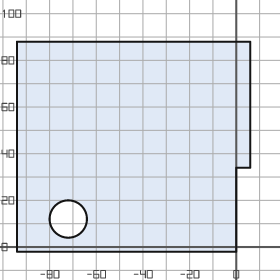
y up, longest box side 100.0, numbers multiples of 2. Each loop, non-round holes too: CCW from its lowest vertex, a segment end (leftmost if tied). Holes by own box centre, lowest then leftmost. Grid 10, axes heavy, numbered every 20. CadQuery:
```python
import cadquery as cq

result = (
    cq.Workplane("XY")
    .moveTo(-94.0, -2.0)
    .lineTo(0.0, -2.0)
    .lineTo(0.0, 34.0)
    .lineTo(6.0, 34.0)
    .lineTo(6.0, 88.0)
    .lineTo(-94.0, 88.0)
    .close()
    .moveTo(-72.0, 12.0)
    .circle(8.0)
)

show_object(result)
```